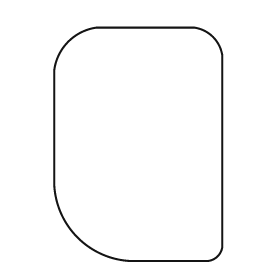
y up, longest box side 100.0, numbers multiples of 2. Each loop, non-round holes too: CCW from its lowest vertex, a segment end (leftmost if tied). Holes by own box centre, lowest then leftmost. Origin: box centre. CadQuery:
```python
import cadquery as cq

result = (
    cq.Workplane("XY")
    .moveTo(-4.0, -50.0)
    .lineTo(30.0, -50.0)
    .threePointArc((34.0, -48.0), (36.0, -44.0))
    .lineTo(36.0, 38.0)
    .threePointArc((32.0, 46.0), (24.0, 50.0))
    .lineTo(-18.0, 50.0)
    .threePointArc((-30.0, 44.0), (-36.0, 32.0))
    .lineTo(-36.0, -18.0)
    .threePointArc((-26.0, -40.0), (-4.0, -50.0))
    .close()
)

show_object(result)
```